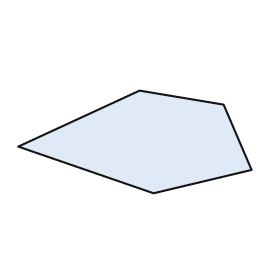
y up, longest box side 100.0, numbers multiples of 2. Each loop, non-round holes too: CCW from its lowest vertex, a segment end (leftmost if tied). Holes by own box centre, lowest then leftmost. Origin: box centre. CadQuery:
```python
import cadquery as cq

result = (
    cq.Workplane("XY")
    .moveTo(8.0, -22.0)
    .lineTo(50.0, -12.0)
    .lineTo(38.0, 16.0)
    .lineTo(2.0, 22.0)
    .lineTo(-50.0, -2.0)
    .close()
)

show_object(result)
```